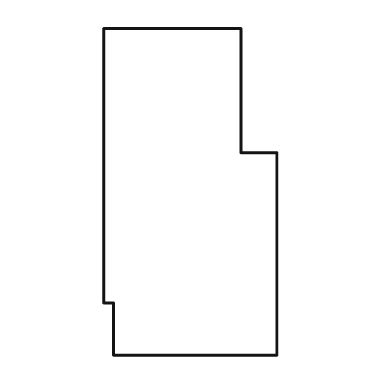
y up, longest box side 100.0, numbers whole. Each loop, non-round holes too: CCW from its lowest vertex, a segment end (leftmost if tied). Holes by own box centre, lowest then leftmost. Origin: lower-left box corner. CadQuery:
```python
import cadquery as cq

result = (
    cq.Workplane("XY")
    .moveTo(3.0, 0.0)
    .lineTo(53.0, 0.0)
    .lineTo(53.0, 62.0)
    .lineTo(42.0, 62.0)
    .lineTo(42.0, 100.0)
    .lineTo(0.0, 100.0)
    .lineTo(0.0, 16.0)
    .lineTo(3.0, 16.0)
    .close()
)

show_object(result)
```